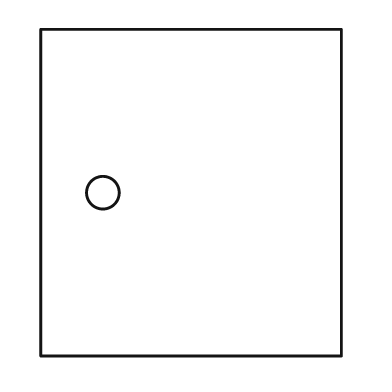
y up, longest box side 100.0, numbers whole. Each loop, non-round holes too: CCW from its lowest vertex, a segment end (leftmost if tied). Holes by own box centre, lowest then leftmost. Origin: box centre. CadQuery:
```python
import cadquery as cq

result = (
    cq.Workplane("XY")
    .moveTo(-46.0, -50.0)
    .lineTo(46.0, -50.0)
    .lineTo(46.0, 50.0)
    .lineTo(-46.0, 50.0)
    .close()
    .moveTo(-27.0, 0.0)
    .circle(5.0)
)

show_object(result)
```